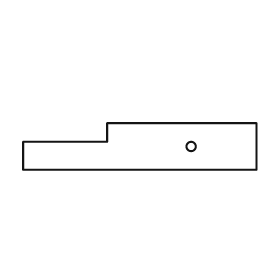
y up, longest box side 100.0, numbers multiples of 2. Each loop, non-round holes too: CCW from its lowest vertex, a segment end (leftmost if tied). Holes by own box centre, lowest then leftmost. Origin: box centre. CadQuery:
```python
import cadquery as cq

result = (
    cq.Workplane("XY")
    .moveTo(-50.0, -10.0)
    .lineTo(50.0, -10.0)
    .lineTo(50.0, 10.0)
    .lineTo(-14.0, 10.0)
    .lineTo(-14.0, 2.0)
    .lineTo(-50.0, 2.0)
    .close()
    .moveTo(22.0, 0.0)
    .circle(2.0)
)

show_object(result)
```